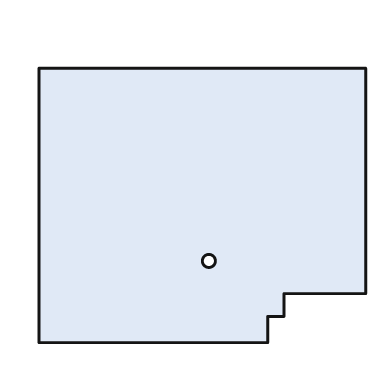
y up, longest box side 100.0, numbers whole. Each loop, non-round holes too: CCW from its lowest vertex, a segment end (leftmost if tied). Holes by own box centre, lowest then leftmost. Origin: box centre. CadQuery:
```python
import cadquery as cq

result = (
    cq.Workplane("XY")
    .moveTo(-50.0, -42.0)
    .lineTo(20.0, -42.0)
    .lineTo(20.0, -34.0)
    .lineTo(25.0, -34.0)
    .lineTo(25.0, -27.0)
    .lineTo(50.0, -27.0)
    .lineTo(50.0, 42.0)
    .lineTo(-50.0, 42.0)
    .close()
    .moveTo(2.0, -17.0)
    .circle(2.0)
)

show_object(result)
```